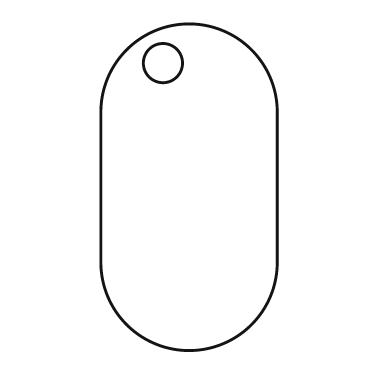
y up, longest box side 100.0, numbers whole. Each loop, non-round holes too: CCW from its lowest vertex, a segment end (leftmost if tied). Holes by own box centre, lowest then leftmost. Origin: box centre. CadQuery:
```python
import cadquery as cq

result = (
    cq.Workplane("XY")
    .moveTo(-27.0, -23.0)
    .threePointArc((0.0, -50.0), (27.0, -23.0))
    .lineTo(27.0, 23.0)
    .threePointArc((0.0, 50.0), (-27.0, 23.0))
    .close()
    .moveTo(-8.0, 38.0)
    .circle(6.0)
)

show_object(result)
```